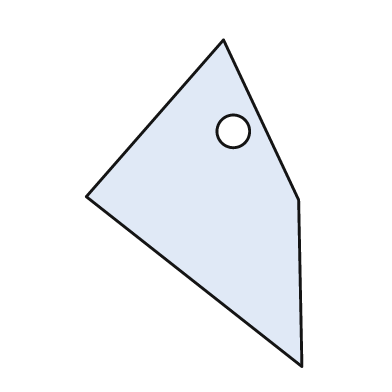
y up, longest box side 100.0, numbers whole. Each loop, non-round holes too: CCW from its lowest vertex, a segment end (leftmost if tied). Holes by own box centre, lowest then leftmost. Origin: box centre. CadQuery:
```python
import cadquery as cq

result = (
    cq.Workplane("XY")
    .moveTo(33.0, -50.0)
    .lineTo(32.0, 1.0)
    .lineTo(9.0, 50.0)
    .lineTo(-33.0, 2.0)
    .close()
    .moveTo(12.0, 22.0)
    .circle(5.0)
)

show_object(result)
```